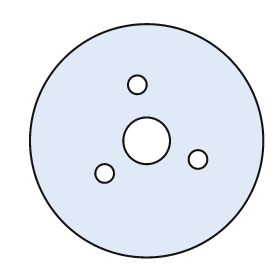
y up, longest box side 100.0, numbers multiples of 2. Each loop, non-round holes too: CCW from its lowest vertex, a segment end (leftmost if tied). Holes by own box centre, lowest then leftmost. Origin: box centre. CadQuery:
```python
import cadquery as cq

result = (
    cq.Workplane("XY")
    .moveTo(0.0, 0.0)
    .circle(50.0)
    .moveTo(-18.0, -14.0)
    .circle(4.0)
    .moveTo(22.0, -8.0)
    .circle(4.0)
    .moveTo(0.0, 0.0)
    .circle(10.0)
    .moveTo(-4.0, 24.0)
    .circle(4.0)
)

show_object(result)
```